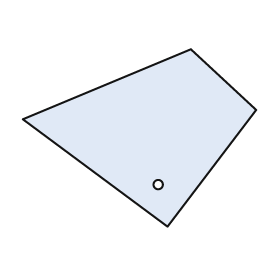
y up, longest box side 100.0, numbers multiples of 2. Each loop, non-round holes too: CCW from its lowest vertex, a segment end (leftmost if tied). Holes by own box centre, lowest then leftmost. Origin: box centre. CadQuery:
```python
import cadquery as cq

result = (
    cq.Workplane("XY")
    .moveTo(12.0, -38.0)
    .lineTo(50.0, 12.0)
    .lineTo(22.0, 38.0)
    .lineTo(-50.0, 8.0)
    .close()
    .moveTo(8.0, -20.0)
    .circle(2.0)
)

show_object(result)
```